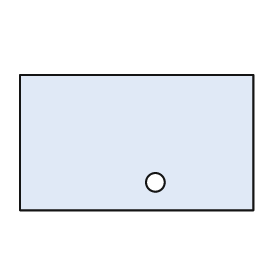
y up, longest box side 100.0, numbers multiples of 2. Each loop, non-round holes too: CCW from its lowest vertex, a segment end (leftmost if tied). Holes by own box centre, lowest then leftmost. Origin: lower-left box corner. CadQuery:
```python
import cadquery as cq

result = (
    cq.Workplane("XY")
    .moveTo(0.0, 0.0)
    .lineTo(100.0, 0.0)
    .lineTo(100.0, 58.0)
    .lineTo(0.0, 58.0)
    .close()
    .moveTo(58.0, 12.0)
    .circle(4.0)
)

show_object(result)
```